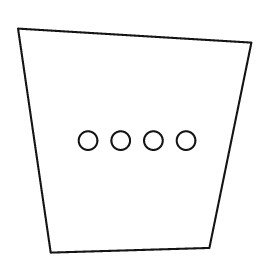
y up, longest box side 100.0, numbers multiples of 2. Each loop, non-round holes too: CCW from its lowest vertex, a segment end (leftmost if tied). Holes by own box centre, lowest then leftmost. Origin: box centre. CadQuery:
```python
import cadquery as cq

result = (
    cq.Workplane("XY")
    .moveTo(-36.0, -48.0)
    .lineTo(32.0, -46.0)
    .lineTo(50.0, 42.0)
    .lineTo(-50.0, 48.0)
    .close()
    .moveTo(-20.0, 0.0)
    .circle(4.0)
    .moveTo(-6.0, 0.0)
    .circle(4.0)
    .moveTo(8.0, 0.0)
    .circle(4.0)
    .moveTo(22.0, 0.0)
    .circle(4.0)
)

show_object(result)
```